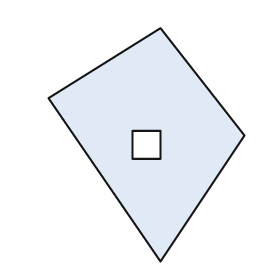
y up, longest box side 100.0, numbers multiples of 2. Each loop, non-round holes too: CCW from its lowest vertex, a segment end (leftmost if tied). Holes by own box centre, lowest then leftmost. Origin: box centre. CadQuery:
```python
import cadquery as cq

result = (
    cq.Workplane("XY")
    .moveTo(6.0, -50.0)
    .lineTo(42.0, 4.0)
    .lineTo(6.0, 50.0)
    .lineTo(-42.0, 20.0)
    .close()
    .moveTo(-6.0, -6.0)
    .lineTo(6.0, -6.0)
    .lineTo(6.0, 6.0)
    .lineTo(-6.0, 6.0)
    .close()
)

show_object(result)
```